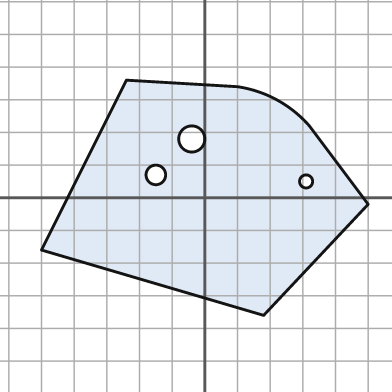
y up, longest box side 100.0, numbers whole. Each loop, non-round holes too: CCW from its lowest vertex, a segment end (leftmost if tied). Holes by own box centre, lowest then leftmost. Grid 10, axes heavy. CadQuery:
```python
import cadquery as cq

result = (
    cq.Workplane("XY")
    .moveTo(18.0, -36.0)
    .lineTo(50.0, -2.0)
    .lineTo(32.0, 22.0)
    .threePointArc((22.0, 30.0), (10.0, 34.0))
    .lineTo(-24.0, 36.0)
    .lineTo(-50.0, -16.0)
    .close()
    .moveTo(31.0, 5.0)
    .circle(2.0)
    .moveTo(-15.0, 7.0)
    .circle(3.0)
    .moveTo(-4.0, 18.0)
    .circle(4.0)
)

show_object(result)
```